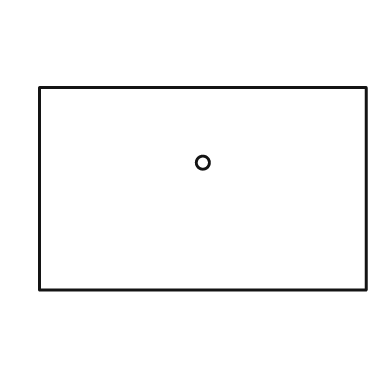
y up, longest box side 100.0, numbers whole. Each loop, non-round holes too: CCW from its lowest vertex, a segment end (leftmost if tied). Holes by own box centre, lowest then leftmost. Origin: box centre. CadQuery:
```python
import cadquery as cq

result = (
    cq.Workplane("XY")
    .moveTo(-50.0, -31.0)
    .lineTo(50.0, -31.0)
    .lineTo(50.0, 31.0)
    .lineTo(-50.0, 31.0)
    .close()
    .moveTo(0.0, 8.0)
    .circle(2.0)
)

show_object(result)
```